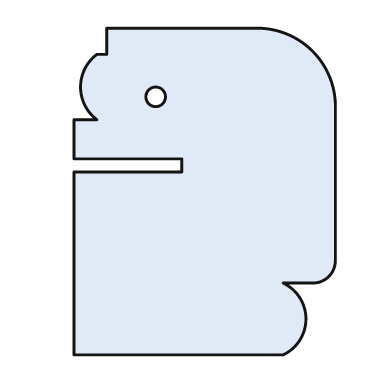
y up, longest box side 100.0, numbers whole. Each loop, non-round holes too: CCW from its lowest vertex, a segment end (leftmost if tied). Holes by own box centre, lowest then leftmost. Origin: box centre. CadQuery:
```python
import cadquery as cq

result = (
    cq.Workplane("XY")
    .moveTo(-40.0, -50.0)
    .lineTo(24.0, -50.0)
    .threePointArc((31.0, -39.0), (24.0, -28.0))
    .lineTo(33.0, -28.0)
    .threePointArc((38.0, -26.0), (40.0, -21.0))
    .lineTo(40.0, 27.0)
    .threePointArc((33.0, 43.0), (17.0, 50.0))
    .lineTo(-30.0, 50.0)
    .lineTo(-30.0, 42.0)
    .lineTo(-33.0, 42.0)
    .threePointArc((-38.0, 32.0), (-33.0, 22.0))
    .lineTo(-40.0, 22.0)
    .lineTo(-40.0, 10.0)
    .lineTo(-7.0, 10.0)
    .lineTo(-7.0, 6.0)
    .lineTo(-40.0, 6.0)
    .close()
    .moveTo(-15.0, 29.0)
    .circle(3.0)
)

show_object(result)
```